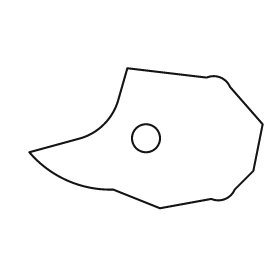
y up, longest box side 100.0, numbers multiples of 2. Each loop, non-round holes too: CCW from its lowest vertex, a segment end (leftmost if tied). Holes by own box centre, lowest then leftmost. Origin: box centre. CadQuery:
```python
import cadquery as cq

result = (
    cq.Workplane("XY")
    .moveTo(6.0, -30.0)
    .lineTo(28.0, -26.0)
    .threePointArc((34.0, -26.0), (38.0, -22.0))
    .lineTo(46.0, -14.0)
    .lineTo(50.0, 6.0)
    .lineTo(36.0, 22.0)
    .threePointArc((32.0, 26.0), (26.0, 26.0))
    .lineTo(-8.0, 30.0)
    .lineTo(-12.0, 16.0)
    .threePointArc((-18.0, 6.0), (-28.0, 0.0))
    .lineTo(-50.0, -6.0)
    .threePointArc((-34.0, -18.0), (-14.0, -22.0))
    .close()
    .moveTo(0.0, 0.0)
    .circle(6.0)
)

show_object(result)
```